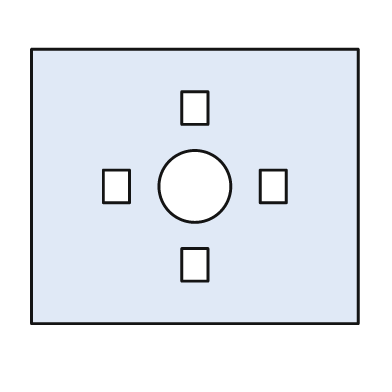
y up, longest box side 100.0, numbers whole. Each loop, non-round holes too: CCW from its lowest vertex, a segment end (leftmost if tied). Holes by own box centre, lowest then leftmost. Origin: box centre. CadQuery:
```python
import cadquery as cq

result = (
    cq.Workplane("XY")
    .moveTo(-50.0, -42.0)
    .lineTo(50.0, -42.0)
    .lineTo(50.0, 42.0)
    .lineTo(-50.0, 42.0)
    .close()
    .moveTo(-4.0, -29.0)
    .lineTo(4.0, -29.0)
    .lineTo(4.0, -19.0)
    .lineTo(-4.0, -19.0)
    .close()
    .moveTo(-28.0, -5.0)
    .lineTo(-20.0, -5.0)
    .lineTo(-20.0, 5.0)
    .lineTo(-28.0, 5.0)
    .close()
    .moveTo(0.0, 0.0)
    .circle(11.0)
    .moveTo(20.0, -5.0)
    .lineTo(28.0, -5.0)
    .lineTo(28.0, 5.0)
    .lineTo(20.0, 5.0)
    .close()
    .moveTo(-4.0, 19.0)
    .lineTo(4.0, 19.0)
    .lineTo(4.0, 29.0)
    .lineTo(-4.0, 29.0)
    .close()
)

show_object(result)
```